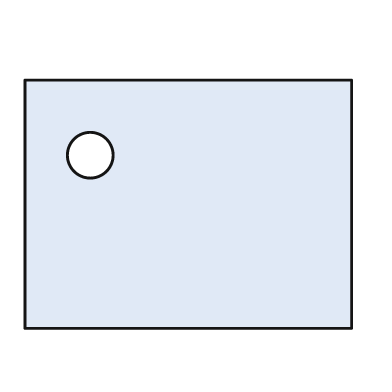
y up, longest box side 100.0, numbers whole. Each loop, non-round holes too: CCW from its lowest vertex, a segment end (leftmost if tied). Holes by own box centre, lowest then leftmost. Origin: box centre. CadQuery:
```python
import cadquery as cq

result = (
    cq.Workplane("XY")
    .moveTo(-50.0, -38.0)
    .lineTo(50.0, -38.0)
    .lineTo(50.0, 38.0)
    .lineTo(-50.0, 38.0)
    .close()
    .moveTo(-30.0, 15.0)
    .circle(7.0)
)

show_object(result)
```